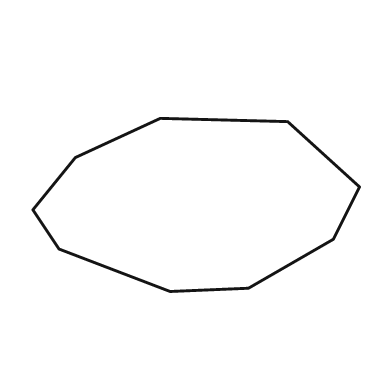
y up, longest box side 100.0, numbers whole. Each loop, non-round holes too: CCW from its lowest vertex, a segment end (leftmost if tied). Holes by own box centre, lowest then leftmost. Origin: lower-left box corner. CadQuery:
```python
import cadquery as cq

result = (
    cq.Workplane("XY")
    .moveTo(42.0, 0.0)
    .lineTo(66.0, 1.0)
    .lineTo(92.0, 16.0)
    .lineTo(100.0, 32.0)
    .lineTo(78.0, 52.0)
    .lineTo(39.0, 53.0)
    .lineTo(13.0, 41.0)
    .lineTo(0.0, 25.0)
    .lineTo(8.0, 13.0)
    .close()
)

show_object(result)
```